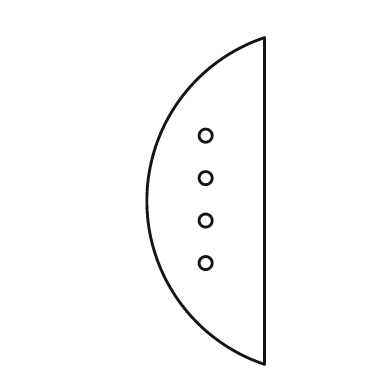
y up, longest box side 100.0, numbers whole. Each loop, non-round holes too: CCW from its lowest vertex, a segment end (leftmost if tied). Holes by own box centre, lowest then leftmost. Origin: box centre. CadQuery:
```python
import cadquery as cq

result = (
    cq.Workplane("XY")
    .moveTo(18.0, -50.0)
    .lineTo(18.0, 50.0)
    .threePointArc((-18.0, 0.0), (18.0, -50.0))
    .close()
    .moveTo(0.0, -19.0)
    .circle(2.0)
    .moveTo(0.0, -6.0)
    .circle(2.0)
    .moveTo(0.0, 7.0)
    .circle(2.0)
    .moveTo(0.0, 20.0)
    .circle(2.0)
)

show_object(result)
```